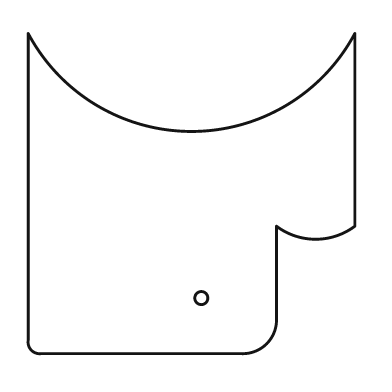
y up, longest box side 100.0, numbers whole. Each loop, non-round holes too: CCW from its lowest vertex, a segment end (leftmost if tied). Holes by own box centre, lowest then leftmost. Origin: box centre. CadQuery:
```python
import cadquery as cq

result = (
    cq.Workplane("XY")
    .moveTo(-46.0, -49.0)
    .lineTo(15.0, -49.0)
    .threePointArc((23.0, -46.0), (26.0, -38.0))
    .lineTo(26.0, -10.0)
    .threePointArc((38.0, -14.0), (50.0, -10.0))
    .lineTo(50.0, 49.0)
    .threePointArc((0.0, 19.0), (-50.0, 49.0))
    .lineTo(-50.0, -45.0)
    .threePointArc((-49.0, -48.0), (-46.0, -49.0))
    .close()
    .moveTo(3.0, -32.0)
    .circle(2.0)
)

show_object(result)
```